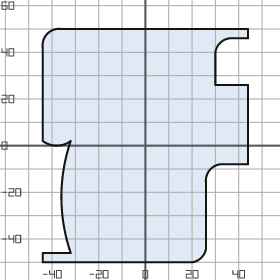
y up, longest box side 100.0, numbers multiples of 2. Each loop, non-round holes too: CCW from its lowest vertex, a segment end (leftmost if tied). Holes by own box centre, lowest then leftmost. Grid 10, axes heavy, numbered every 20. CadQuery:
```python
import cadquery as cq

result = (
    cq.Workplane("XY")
    .moveTo(-44.0, -50.0)
    .lineTo(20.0, -50.0)
    .threePointArc((24.0, -48.0), (26.0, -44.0))
    .lineTo(26.0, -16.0)
    .threePointArc((28.0, -10.0), (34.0, -8.0))
    .lineTo(44.0, -8.0)
    .lineTo(44.0, 26.0)
    .lineTo(30.0, 26.0)
    .lineTo(30.0, 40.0)
    .threePointArc((32.0, 44.0), (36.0, 46.0))
    .lineTo(44.0, 46.0)
    .lineTo(44.0, 50.0)
    .lineTo(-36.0, 50.0)
    .threePointArc((-42.0, 48.0), (-44.0, 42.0))
    .lineTo(-44.0, 2.0)
    .threePointArc((-38.0, 0.0), (-32.0, 2.0))
    .threePointArc((-36.0, -22.0), (-32.0, -46.0))
    .lineTo(-44.0, -46.0)
    .close()
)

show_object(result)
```